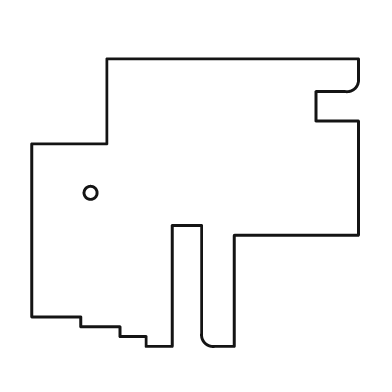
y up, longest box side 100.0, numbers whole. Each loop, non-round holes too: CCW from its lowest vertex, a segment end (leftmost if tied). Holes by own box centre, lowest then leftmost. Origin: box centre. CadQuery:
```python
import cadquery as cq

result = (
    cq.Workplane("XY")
    .moveTo(-15.0, -44.0)
    .lineTo(-7.0, -44.0)
    .lineTo(-7.0, -7.0)
    .lineTo(2.0, -7.0)
    .lineTo(2.0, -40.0)
    .threePointArc((3.0, -43.0), (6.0, -44.0))
    .lineTo(12.0, -44.0)
    .lineTo(12.0, -10.0)
    .lineTo(50.0, -10.0)
    .lineTo(50.0, 25.0)
    .lineTo(37.0, 25.0)
    .lineTo(37.0, 34.0)
    .lineTo(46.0, 34.0)
    .threePointArc((49.0, 35.0), (50.0, 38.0))
    .lineTo(50.0, 44.0)
    .lineTo(-27.0, 44.0)
    .lineTo(-27.0, 18.0)
    .lineTo(-50.0, 18.0)
    .lineTo(-50.0, -35.0)
    .lineTo(-35.0, -35.0)
    .lineTo(-35.0, -38.0)
    .lineTo(-23.0, -38.0)
    .lineTo(-23.0, -41.0)
    .lineTo(-15.0, -41.0)
    .close()
    .moveTo(-32.0, 3.0)
    .circle(2.0)
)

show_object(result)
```